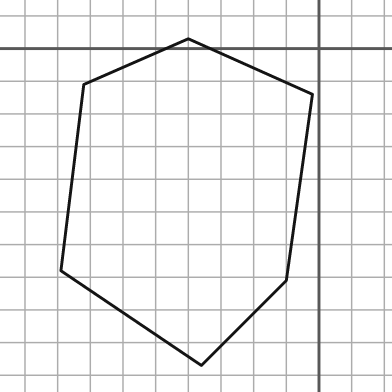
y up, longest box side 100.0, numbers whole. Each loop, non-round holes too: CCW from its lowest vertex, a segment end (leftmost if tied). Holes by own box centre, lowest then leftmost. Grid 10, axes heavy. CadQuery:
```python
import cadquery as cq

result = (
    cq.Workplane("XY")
    .moveTo(-36.0, -97.0)
    .lineTo(-10.0, -71.0)
    .lineTo(-2.0, -14.0)
    .lineTo(-40.0, 3.0)
    .lineTo(-72.0, -11.0)
    .lineTo(-79.0, -68.0)
    .close()
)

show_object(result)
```